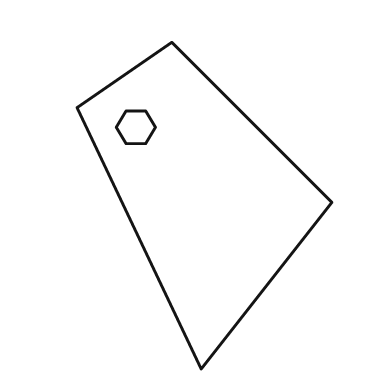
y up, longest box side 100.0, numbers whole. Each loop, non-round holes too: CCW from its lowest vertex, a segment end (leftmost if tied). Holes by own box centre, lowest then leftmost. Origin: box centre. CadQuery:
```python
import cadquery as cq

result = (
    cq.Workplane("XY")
    .moveTo(-1.0, -50.0)
    .lineTo(39.0, 1.0)
    .lineTo(-10.0, 50.0)
    .lineTo(-39.0, 30.0)
    .close()
    .moveTo(-24.0, 19.0)
    .lineTo(-18.0, 19.0)
    .lineTo(-15.0, 24.0)
    .lineTo(-18.0, 29.0)
    .lineTo(-24.0, 29.0)
    .lineTo(-27.0, 24.0)
    .close()
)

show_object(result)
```